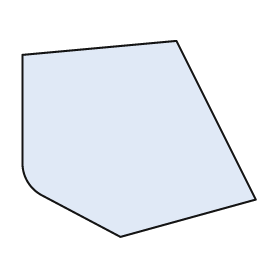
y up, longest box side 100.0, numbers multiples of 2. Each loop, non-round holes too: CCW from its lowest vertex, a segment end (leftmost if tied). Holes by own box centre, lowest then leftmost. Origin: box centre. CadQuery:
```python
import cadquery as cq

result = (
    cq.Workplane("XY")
    .moveTo(-8.0, -42.0)
    .lineTo(50.0, -26.0)
    .lineTo(16.0, 42.0)
    .lineTo(-50.0, 36.0)
    .lineTo(-50.0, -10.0)
    .threePointArc((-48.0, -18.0), (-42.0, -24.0))
    .close()
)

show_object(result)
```